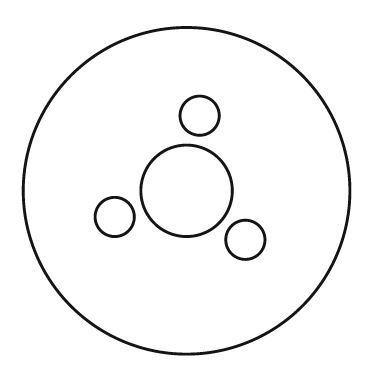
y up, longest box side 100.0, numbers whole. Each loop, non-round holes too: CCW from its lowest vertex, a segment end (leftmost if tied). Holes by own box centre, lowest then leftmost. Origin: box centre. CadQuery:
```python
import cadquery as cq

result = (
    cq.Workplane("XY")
    .moveTo(0.0, 0.0)
    .circle(50.0)
    .moveTo(18.0, -15.0)
    .circle(6.0)
    .moveTo(-22.0, -8.0)
    .circle(6.0)
    .moveTo(0.0, 0.0)
    .circle(14.0)
    .moveTo(4.0, 23.0)
    .circle(6.0)
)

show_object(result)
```